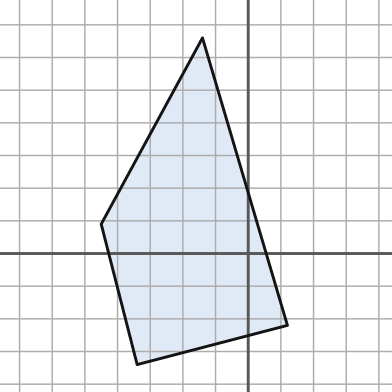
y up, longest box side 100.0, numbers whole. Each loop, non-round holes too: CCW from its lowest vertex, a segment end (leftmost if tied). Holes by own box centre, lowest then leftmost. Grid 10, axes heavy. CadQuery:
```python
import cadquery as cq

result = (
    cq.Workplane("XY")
    .moveTo(-34.0, -34.0)
    .lineTo(12.0, -22.0)
    .lineTo(-14.0, 66.0)
    .lineTo(-45.0, 9.0)
    .close()
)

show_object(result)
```